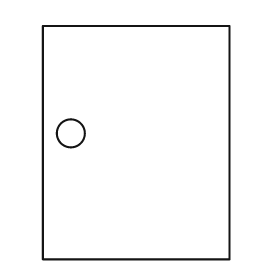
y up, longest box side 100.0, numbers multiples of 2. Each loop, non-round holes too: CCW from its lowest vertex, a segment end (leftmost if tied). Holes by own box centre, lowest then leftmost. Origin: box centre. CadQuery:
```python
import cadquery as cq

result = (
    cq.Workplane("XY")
    .moveTo(-40.0, -50.0)
    .lineTo(40.0, -50.0)
    .lineTo(40.0, 50.0)
    .lineTo(-40.0, 50.0)
    .close()
    .moveTo(-28.0, 4.0)
    .circle(6.0)
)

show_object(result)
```